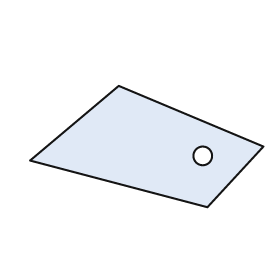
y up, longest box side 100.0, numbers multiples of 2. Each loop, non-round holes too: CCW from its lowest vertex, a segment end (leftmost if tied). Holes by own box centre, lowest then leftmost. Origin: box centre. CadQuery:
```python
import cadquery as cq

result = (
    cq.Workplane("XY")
    .moveTo(26.0, -26.0)
    .lineTo(50.0, 0.0)
    .lineTo(-12.0, 26.0)
    .lineTo(-50.0, -6.0)
    .close()
    .moveTo(24.0, -4.0)
    .circle(4.0)
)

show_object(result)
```